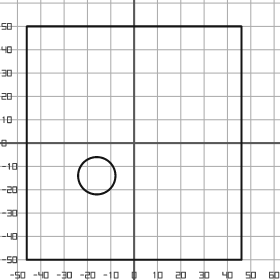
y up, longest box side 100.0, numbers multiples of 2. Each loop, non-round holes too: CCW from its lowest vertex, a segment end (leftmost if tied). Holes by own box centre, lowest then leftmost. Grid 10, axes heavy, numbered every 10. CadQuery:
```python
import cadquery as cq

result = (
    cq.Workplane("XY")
    .moveTo(-46.0, -50.0)
    .lineTo(46.0, -50.0)
    .lineTo(46.0, 50.0)
    .lineTo(-46.0, 50.0)
    .close()
    .moveTo(-16.0, -14.0)
    .circle(8.0)
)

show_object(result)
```